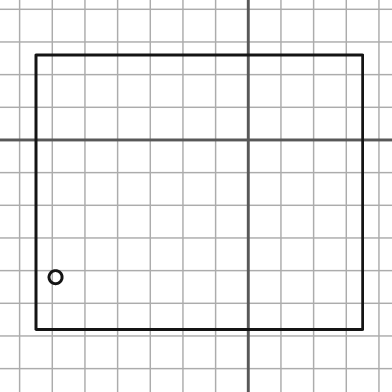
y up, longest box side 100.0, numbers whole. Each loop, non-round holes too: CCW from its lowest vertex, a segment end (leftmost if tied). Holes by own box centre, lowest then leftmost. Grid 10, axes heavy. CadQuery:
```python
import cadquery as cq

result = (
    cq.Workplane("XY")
    .moveTo(-65.0, -58.0)
    .lineTo(35.0, -58.0)
    .lineTo(35.0, 26.0)
    .lineTo(-65.0, 26.0)
    .close()
    .moveTo(-59.0, -42.0)
    .circle(2.0)
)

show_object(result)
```